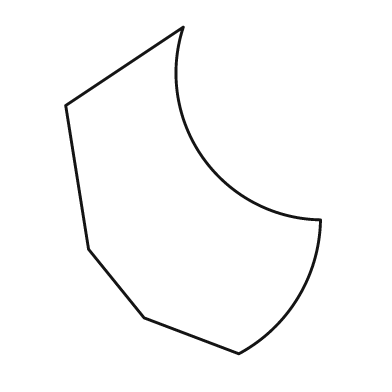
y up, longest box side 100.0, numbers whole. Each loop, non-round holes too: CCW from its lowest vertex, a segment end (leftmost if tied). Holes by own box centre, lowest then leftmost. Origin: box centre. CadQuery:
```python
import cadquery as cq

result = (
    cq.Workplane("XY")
    .moveTo(14.0, -50.0)
    .threePointArc((32.0, -33.0), (39.0, -9.0))
    .threePointArc((3.0, 10.0), (-3.0, 50.0))
    .lineTo(-39.0, 26.0)
    .lineTo(-32.0, -18.0)
    .lineTo(-15.0, -39.0)
    .close()
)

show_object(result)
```